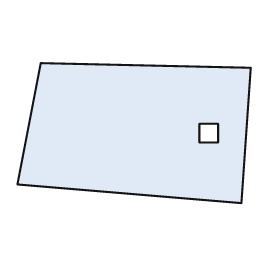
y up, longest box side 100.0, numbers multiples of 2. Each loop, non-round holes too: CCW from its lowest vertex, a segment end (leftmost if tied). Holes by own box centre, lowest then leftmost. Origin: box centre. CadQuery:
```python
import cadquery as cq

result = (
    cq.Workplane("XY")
    .moveTo(46.0, -30.0)
    .lineTo(50.0, 28.0)
    .lineTo(-40.0, 30.0)
    .lineTo(-50.0, -22.0)
    .close()
    .moveTo(28.0, -4.0)
    .lineTo(36.0, -4.0)
    .lineTo(36.0, 4.0)
    .lineTo(28.0, 4.0)
    .close()
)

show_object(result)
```